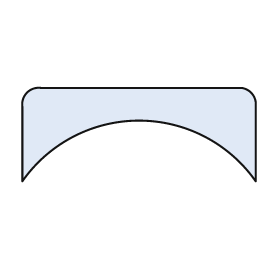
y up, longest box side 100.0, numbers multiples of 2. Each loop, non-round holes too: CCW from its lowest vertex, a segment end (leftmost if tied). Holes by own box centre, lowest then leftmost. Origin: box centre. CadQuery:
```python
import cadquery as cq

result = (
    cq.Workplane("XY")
    .moveTo(-50.0, -20.0)
    .threePointArc((0.0, 6.0), (50.0, -20.0))
    .lineTo(50.0, 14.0)
    .threePointArc((48.0, 18.0), (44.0, 20.0))
    .lineTo(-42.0, 20.0)
    .threePointArc((-48.0, 18.0), (-50.0, 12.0))
    .close()
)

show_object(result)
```